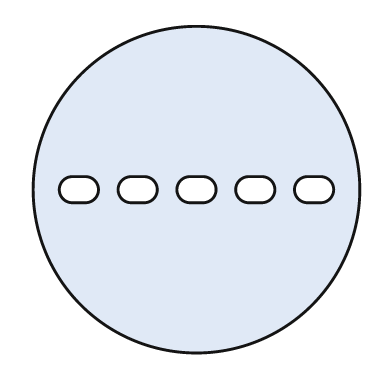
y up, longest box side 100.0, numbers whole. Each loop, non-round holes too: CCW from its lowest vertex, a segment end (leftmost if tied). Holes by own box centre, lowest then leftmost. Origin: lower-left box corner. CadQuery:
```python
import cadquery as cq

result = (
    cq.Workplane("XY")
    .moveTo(50.0, 50.0)
    .circle(50.0)
    .moveTo(12.0, 46.0)
    .lineTo(16.0, 46.0)
    .threePointArc((20.0, 50.0), (16.0, 54.0))
    .lineTo(12.0, 54.0)
    .threePointArc((8.0, 50.0), (12.0, 46.0))
    .close()
    .moveTo(30.0, 46.0)
    .lineTo(34.0, 46.0)
    .threePointArc((38.0, 50.0), (34.0, 54.0))
    .lineTo(30.0, 54.0)
    .threePointArc((26.0, 50.0), (30.0, 46.0))
    .close()
    .moveTo(48.0, 46.0)
    .lineTo(52.0, 46.0)
    .threePointArc((56.0, 50.0), (52.0, 54.0))
    .lineTo(48.0, 54.0)
    .threePointArc((44.0, 50.0), (48.0, 46.0))
    .close()
    .moveTo(66.0, 46.0)
    .lineTo(70.0, 46.0)
    .threePointArc((74.0, 50.0), (70.0, 54.0))
    .lineTo(66.0, 54.0)
    .threePointArc((62.0, 50.0), (66.0, 46.0))
    .close()
    .moveTo(84.0, 46.0)
    .lineTo(88.0, 46.0)
    .threePointArc((92.0, 50.0), (88.0, 54.0))
    .lineTo(84.0, 54.0)
    .threePointArc((80.0, 50.0), (84.0, 46.0))
    .close()
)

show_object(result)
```